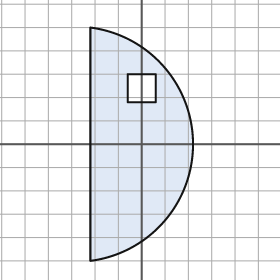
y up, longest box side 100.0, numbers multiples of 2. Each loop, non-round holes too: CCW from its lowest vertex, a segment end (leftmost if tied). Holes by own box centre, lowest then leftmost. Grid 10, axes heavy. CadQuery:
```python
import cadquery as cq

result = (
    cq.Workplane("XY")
    .moveTo(-22.0, -50.0)
    .threePointArc((22.0, 0.0), (-22.0, 50.0))
    .close()
    .moveTo(-6.0, 18.0)
    .lineTo(6.0, 18.0)
    .lineTo(6.0, 30.0)
    .lineTo(-6.0, 30.0)
    .close()
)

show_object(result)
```